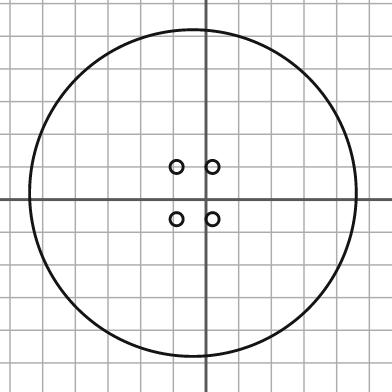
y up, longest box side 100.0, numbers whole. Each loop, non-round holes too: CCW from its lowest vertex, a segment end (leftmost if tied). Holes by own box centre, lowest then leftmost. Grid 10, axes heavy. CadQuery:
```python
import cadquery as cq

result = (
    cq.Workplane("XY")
    .moveTo(-4.0, 2.0)
    .circle(50.0)
    .moveTo(-9.0, -6.0)
    .circle(2.0)
    .moveTo(2.0, -6.0)
    .circle(2.0)
    .moveTo(-9.0, 10.0)
    .circle(2.0)
    .moveTo(2.0, 10.0)
    .circle(2.0)
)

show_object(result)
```